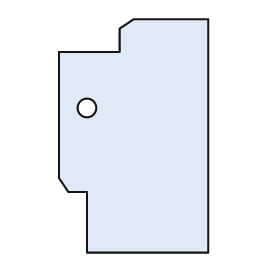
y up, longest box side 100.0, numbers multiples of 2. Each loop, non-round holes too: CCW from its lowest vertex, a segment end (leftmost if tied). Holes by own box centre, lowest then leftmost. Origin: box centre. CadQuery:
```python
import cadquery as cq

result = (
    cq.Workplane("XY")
    .moveTo(-20.0, -50.0)
    .lineTo(32.0, -50.0)
    .lineTo(32.0, 50.0)
    .lineTo(0.0, 50.0)
    .lineTo(-6.0, 46.0)
    .lineTo(-6.0, 36.0)
    .lineTo(-32.0, 36.0)
    .lineTo(-32.0, -18.0)
    .lineTo(-28.0, -24.0)
    .lineTo(-20.0, -24.0)
    .close()
    .moveTo(-20.0, 12.0)
    .circle(4.0)
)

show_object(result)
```